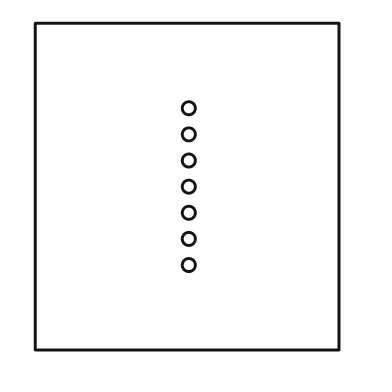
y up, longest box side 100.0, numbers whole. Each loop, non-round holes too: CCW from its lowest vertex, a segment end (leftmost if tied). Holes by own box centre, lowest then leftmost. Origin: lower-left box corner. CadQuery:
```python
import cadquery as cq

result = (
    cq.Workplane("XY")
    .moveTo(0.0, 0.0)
    .lineTo(93.0, 0.0)
    .lineTo(93.0, 100.0)
    .lineTo(0.0, 100.0)
    .close()
    .moveTo(47.0, 26.0)
    .circle(2.0)
    .moveTo(47.0, 34.0)
    .circle(2.0)
    .moveTo(47.0, 42.0)
    .circle(2.0)
    .moveTo(47.0, 50.0)
    .circle(2.0)
    .moveTo(47.0, 58.0)
    .circle(2.0)
    .moveTo(47.0, 66.0)
    .circle(2.0)
    .moveTo(47.0, 74.0)
    .circle(2.0)
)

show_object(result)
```